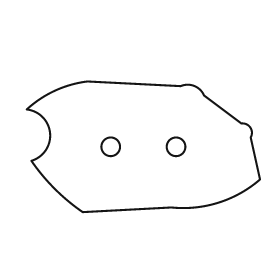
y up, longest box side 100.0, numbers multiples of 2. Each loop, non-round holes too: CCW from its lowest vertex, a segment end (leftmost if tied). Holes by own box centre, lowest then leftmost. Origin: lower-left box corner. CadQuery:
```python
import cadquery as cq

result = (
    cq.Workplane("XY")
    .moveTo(24.0, 0.0)
    .lineTo(62.0, 2.0)
    .threePointArc((82.0, 4.0), (100.0, 14.0))
    .lineTo(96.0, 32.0)
    .threePointArc((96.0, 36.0), (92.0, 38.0))
    .lineTo(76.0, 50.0)
    .threePointArc((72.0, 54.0), (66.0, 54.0))
    .lineTo(26.0, 56.0)
    .threePointArc((12.0, 52.0), (0.0, 44.0))
    .threePointArc((10.0, 34.0), (2.0, 22.0))
    .threePointArc((12.0, 10.0), (24.0, 0.0))
    .close()
    .moveTo(36.0, 28.0)
    .circle(4.0)
    .moveTo(64.0, 28.0)
    .circle(4.0)
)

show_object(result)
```